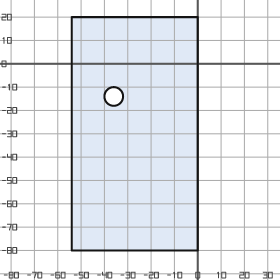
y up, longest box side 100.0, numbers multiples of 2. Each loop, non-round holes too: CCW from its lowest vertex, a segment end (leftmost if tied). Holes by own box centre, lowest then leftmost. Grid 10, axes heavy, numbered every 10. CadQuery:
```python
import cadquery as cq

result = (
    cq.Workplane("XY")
    .moveTo(-54.0, -80.0)
    .lineTo(0.0, -80.0)
    .lineTo(0.0, 20.0)
    .lineTo(-54.0, 20.0)
    .close()
    .moveTo(-36.0, -14.0)
    .circle(4.0)
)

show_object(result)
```